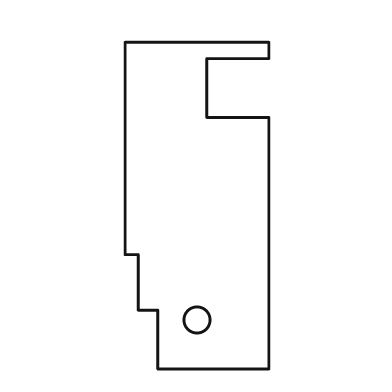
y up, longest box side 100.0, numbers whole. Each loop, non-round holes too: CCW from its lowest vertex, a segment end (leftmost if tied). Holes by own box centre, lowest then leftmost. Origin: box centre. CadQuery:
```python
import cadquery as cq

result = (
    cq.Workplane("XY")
    .moveTo(-12.0, -50.0)
    .lineTo(22.0, -50.0)
    .lineTo(22.0, 27.0)
    .lineTo(3.0, 27.0)
    .lineTo(3.0, 45.0)
    .lineTo(22.0, 45.0)
    .lineTo(22.0, 50.0)
    .lineTo(-22.0, 50.0)
    .lineTo(-22.0, -15.0)
    .lineTo(-18.0, -15.0)
    .lineTo(-18.0, -32.0)
    .lineTo(-12.0, -32.0)
    .close()
    .moveTo(0.0, -35.0)
    .circle(4.0)
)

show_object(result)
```